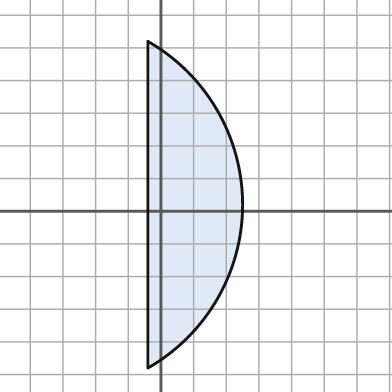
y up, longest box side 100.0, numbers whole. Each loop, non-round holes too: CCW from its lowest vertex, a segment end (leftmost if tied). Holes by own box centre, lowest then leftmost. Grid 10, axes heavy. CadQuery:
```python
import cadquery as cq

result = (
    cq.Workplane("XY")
    .moveTo(-4.0, -48.0)
    .threePointArc((25.0, 2.0), (-4.0, 52.0))
    .close()
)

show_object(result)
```